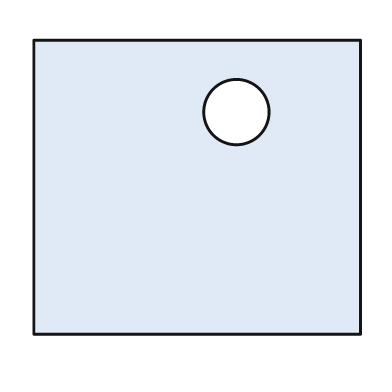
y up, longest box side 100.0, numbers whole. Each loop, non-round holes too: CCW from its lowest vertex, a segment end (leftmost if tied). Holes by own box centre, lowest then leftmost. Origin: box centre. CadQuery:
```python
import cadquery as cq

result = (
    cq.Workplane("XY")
    .moveTo(-50.0, -45.0)
    .lineTo(50.0, -45.0)
    .lineTo(50.0, 45.0)
    .lineTo(-50.0, 45.0)
    .close()
    .moveTo(12.0, 23.0)
    .circle(10.0)
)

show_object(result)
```